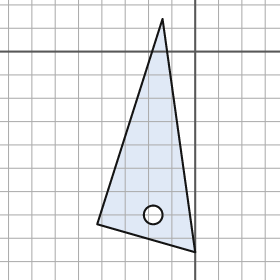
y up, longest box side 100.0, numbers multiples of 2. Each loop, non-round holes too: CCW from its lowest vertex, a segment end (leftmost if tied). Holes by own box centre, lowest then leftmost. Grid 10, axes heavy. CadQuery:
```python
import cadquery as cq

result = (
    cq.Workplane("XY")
    .moveTo(0.0, -86.0)
    .lineTo(-14.0, 14.0)
    .lineTo(-42.0, -74.0)
    .close()
    .moveTo(-18.0, -70.0)
    .circle(4.0)
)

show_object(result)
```